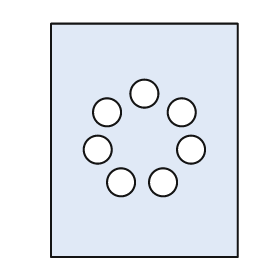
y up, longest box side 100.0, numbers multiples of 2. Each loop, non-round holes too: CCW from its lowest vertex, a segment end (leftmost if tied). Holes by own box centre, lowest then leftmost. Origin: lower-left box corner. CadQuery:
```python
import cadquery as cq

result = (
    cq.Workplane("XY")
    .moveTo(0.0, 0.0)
    .lineTo(80.0, 0.0)
    .lineTo(80.0, 100.0)
    .lineTo(0.0, 100.0)
    .close()
    .moveTo(30.0, 32.0)
    .circle(6.0)
    .moveTo(48.0, 32.0)
    .circle(6.0)
    .moveTo(20.0, 46.0)
    .circle(6.0)
    .moveTo(60.0, 46.0)
    .circle(6.0)
    .moveTo(24.0, 62.0)
    .circle(6.0)
    .moveTo(56.0, 62.0)
    .circle(6.0)
    .moveTo(40.0, 70.0)
    .circle(6.0)
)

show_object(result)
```